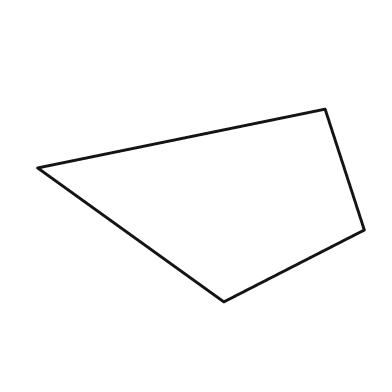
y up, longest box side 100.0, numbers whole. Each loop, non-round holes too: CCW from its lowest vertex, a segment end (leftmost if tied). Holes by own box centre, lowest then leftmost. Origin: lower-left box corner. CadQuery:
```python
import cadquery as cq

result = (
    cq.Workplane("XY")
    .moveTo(57.0, 0.0)
    .lineTo(100.0, 22.0)
    .lineTo(88.0, 59.0)
    .lineTo(0.0, 41.0)
    .close()
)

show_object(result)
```